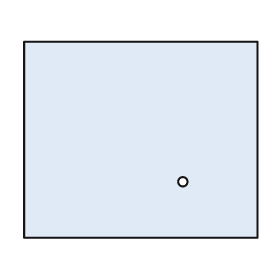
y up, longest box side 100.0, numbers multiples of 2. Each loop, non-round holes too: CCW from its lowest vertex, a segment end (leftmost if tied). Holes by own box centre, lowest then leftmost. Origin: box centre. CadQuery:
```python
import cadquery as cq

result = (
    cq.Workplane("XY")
    .moveTo(-50.0, -42.0)
    .lineTo(50.0, -42.0)
    .lineTo(50.0, 42.0)
    .lineTo(-50.0, 42.0)
    .close()
    .moveTo(18.0, -18.0)
    .circle(2.0)
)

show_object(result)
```